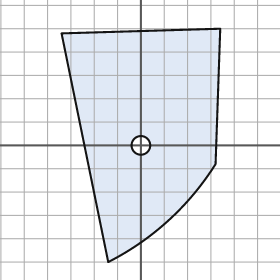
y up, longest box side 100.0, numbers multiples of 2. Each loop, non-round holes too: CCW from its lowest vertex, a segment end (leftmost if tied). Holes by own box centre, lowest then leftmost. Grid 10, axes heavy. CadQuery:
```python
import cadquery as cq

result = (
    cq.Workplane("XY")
    .moveTo(-14.0, -50.0)
    .threePointArc((12.0, -32.0), (32.0, -8.0))
    .lineTo(34.0, 50.0)
    .lineTo(-34.0, 48.0)
    .close()
    .moveTo(0.0, 0.0)
    .circle(4.0)
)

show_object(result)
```